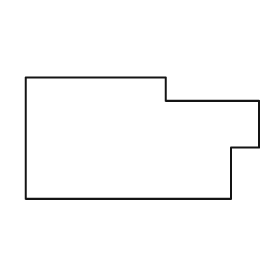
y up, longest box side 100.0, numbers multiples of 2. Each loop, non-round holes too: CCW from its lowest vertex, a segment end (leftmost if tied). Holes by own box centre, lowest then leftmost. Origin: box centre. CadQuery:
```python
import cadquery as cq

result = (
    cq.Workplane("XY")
    .moveTo(-50.0, -26.0)
    .lineTo(38.0, -26.0)
    .lineTo(38.0, -4.0)
    .lineTo(50.0, -4.0)
    .lineTo(50.0, 16.0)
    .lineTo(10.0, 16.0)
    .lineTo(10.0, 26.0)
    .lineTo(-50.0, 26.0)
    .close()
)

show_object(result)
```